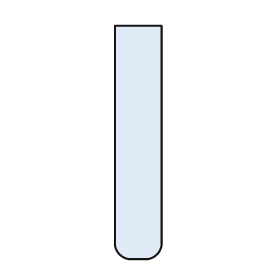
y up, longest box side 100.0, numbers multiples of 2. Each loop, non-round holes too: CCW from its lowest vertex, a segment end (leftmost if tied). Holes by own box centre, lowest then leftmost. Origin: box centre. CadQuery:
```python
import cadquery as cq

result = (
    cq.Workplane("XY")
    .moveTo(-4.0, -50.0)
    .lineTo(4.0, -50.0)
    .threePointArc((8.0, -48.0), (10.0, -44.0))
    .lineTo(10.0, 50.0)
    .lineTo(-10.0, 50.0)
    .lineTo(-10.0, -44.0)
    .threePointArc((-8.0, -48.0), (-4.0, -50.0))
    .close()
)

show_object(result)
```